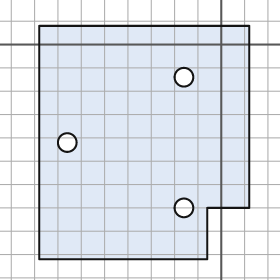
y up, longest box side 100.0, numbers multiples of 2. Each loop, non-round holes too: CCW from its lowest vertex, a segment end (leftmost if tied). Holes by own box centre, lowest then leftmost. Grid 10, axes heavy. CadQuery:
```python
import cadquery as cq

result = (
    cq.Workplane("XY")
    .moveTo(-78.0, -92.0)
    .lineTo(-6.0, -92.0)
    .lineTo(-6.0, -70.0)
    .lineTo(12.0, -70.0)
    .lineTo(12.0, 8.0)
    .lineTo(-78.0, 8.0)
    .close()
    .moveTo(-16.0, -70.0)
    .circle(4.0)
    .moveTo(-66.0, -42.0)
    .circle(4.0)
    .moveTo(-16.0, -14.0)
    .circle(4.0)
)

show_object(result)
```